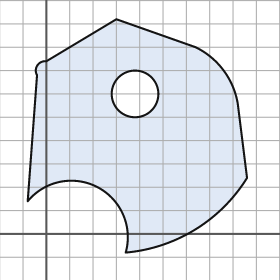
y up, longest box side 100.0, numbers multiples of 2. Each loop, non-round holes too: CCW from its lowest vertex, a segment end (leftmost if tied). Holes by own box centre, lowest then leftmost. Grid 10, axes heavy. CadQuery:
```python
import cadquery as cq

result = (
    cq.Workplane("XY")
    .moveTo(34.0, -8.0)
    .threePointArc((64.0, 2.0), (86.0, 24.0))
    .lineTo(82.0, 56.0)
    .threePointArc((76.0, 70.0), (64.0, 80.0))
    .lineTo(30.0, 92.0)
    .lineTo(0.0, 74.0)
    .threePointArc((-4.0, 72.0), (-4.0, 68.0))
    .lineTo(-8.0, 14.0)
    .threePointArc((22.0, 20.0), (34.0, -8.0))
    .close()
    .moveTo(38.0, 60.0)
    .circle(10.0)
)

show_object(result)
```